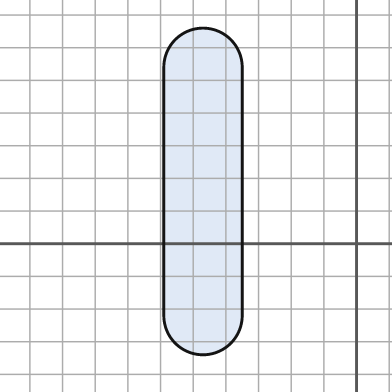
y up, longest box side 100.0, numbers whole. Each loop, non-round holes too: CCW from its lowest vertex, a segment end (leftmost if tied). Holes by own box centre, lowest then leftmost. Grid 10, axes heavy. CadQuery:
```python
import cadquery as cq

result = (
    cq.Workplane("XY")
    .moveTo(-59.0, -22.0)
    .threePointArc((-47.0, -34.0), (-35.0, -22.0))
    .lineTo(-35.0, 54.0)
    .threePointArc((-47.0, 66.0), (-59.0, 54.0))
    .close()
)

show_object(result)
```